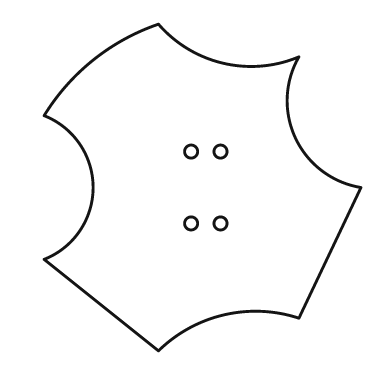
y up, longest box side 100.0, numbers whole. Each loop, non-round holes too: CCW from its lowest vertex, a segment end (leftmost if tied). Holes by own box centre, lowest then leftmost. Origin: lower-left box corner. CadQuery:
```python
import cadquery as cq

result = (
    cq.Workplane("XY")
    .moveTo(35.0, 0.0)
    .threePointArc((55.0, 11.0), (78.0, 10.0))
    .lineTo(97.0, 50.0)
    .threePointArc((77.0, 65.0), (78.0, 90.0))
    .threePointArc((55.0, 88.0), (35.0, 100.0))
    .threePointArc((15.0, 89.0), (0.0, 72.0))
    .threePointArc((15.0, 50.0), (0.0, 28.0))
    .close()
    .moveTo(45.0, 39.0)
    .circle(2.0)
    .moveTo(54.0, 39.0)
    .circle(2.0)
    .moveTo(45.0, 61.0)
    .circle(2.0)
    .moveTo(54.0, 61.0)
    .circle(2.0)
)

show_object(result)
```